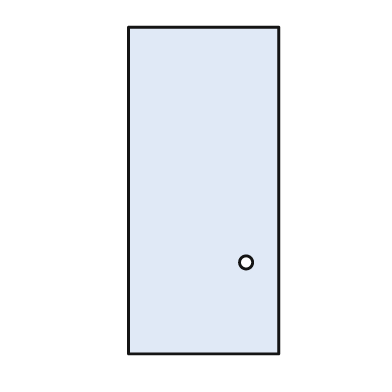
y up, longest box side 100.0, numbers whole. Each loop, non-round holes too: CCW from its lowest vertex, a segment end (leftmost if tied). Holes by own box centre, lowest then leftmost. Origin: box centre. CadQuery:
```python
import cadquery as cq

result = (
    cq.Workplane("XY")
    .moveTo(-23.0, -50.0)
    .lineTo(23.0, -50.0)
    .lineTo(23.0, 50.0)
    .lineTo(-23.0, 50.0)
    .close()
    .moveTo(13.0, -22.0)
    .circle(2.0)
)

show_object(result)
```